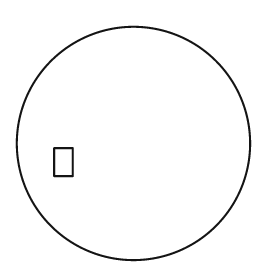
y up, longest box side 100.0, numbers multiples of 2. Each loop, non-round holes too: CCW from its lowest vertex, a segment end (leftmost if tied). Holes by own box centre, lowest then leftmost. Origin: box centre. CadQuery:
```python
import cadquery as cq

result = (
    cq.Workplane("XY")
    .moveTo(0.0, 0.0)
    .circle(50.0)
    .moveTo(-34.0, -14.0)
    .lineTo(-26.0, -14.0)
    .lineTo(-26.0, -2.0)
    .lineTo(-34.0, -2.0)
    .close()
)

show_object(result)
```